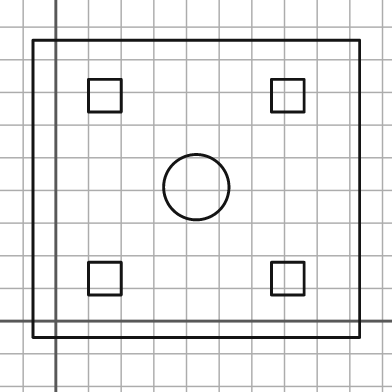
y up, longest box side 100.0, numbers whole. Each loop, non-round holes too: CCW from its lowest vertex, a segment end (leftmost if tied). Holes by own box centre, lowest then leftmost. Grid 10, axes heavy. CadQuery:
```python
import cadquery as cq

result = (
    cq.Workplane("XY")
    .moveTo(-7.0, -5.0)
    .lineTo(93.0, -5.0)
    .lineTo(93.0, 86.0)
    .lineTo(-7.0, 86.0)
    .close()
    .moveTo(10.0, 8.0)
    .lineTo(20.0, 8.0)
    .lineTo(20.0, 18.0)
    .lineTo(10.0, 18.0)
    .close()
    .moveTo(66.0, 8.0)
    .lineTo(76.0, 8.0)
    .lineTo(76.0, 18.0)
    .lineTo(66.0, 18.0)
    .close()
    .moveTo(43.0, 41.0)
    .circle(10.0)
    .moveTo(10.0, 64.0)
    .lineTo(20.0, 64.0)
    .lineTo(20.0, 74.0)
    .lineTo(10.0, 74.0)
    .close()
    .moveTo(66.0, 64.0)
    .lineTo(76.0, 64.0)
    .lineTo(76.0, 74.0)
    .lineTo(66.0, 74.0)
    .close()
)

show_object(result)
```